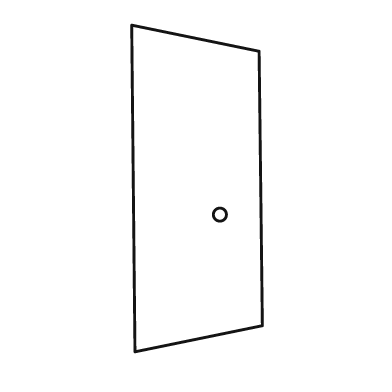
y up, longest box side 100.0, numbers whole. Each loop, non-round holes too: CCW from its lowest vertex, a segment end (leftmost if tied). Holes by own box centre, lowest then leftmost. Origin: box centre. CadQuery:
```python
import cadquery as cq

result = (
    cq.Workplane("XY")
    .moveTo(-19.0, -50.0)
    .lineTo(20.0, -42.0)
    .lineTo(19.0, 42.0)
    .lineTo(-20.0, 50.0)
    .close()
    .moveTo(7.0, -8.0)
    .circle(2.0)
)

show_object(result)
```